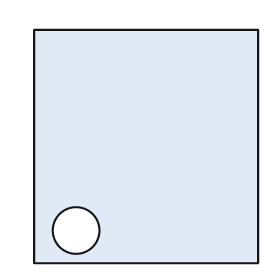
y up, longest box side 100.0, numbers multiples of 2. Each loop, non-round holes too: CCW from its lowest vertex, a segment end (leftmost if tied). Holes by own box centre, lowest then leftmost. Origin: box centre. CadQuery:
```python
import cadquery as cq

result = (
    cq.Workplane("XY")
    .moveTo(-48.0, -50.0)
    .lineTo(48.0, -50.0)
    .lineTo(48.0, 50.0)
    .lineTo(-48.0, 50.0)
    .close()
    .moveTo(-30.0, -36.0)
    .circle(10.0)
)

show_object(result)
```